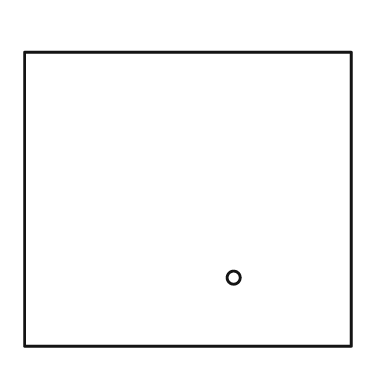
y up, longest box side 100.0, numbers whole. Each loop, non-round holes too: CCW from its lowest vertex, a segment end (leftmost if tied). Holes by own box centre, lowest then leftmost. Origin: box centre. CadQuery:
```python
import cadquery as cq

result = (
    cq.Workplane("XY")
    .moveTo(-50.0, -45.0)
    .lineTo(50.0, -45.0)
    .lineTo(50.0, 45.0)
    .lineTo(-50.0, 45.0)
    .close()
    .moveTo(14.0, -24.0)
    .circle(2.0)
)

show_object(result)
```